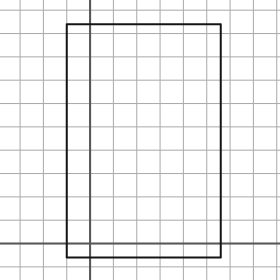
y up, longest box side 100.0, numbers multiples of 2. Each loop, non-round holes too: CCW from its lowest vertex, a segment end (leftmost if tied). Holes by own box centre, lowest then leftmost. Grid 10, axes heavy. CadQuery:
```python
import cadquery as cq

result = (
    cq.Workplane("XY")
    .moveTo(-10.0, -6.0)
    .lineTo(56.0, -6.0)
    .lineTo(56.0, 94.0)
    .lineTo(-10.0, 94.0)
    .close()
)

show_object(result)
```